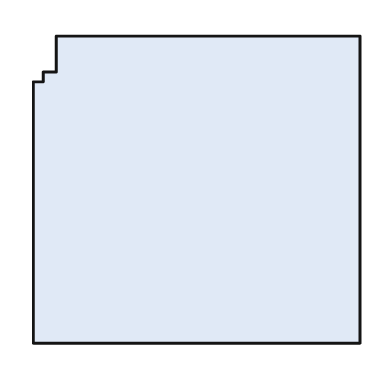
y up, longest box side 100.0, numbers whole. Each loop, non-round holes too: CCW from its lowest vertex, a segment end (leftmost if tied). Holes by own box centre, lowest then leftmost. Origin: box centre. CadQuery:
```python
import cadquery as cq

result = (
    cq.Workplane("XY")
    .moveTo(-50.0, -47.0)
    .lineTo(50.0, -47.0)
    .lineTo(50.0, 47.0)
    .lineTo(-43.0, 47.0)
    .lineTo(-43.0, 36.0)
    .lineTo(-47.0, 36.0)
    .lineTo(-47.0, 33.0)
    .lineTo(-50.0, 33.0)
    .close()
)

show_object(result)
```